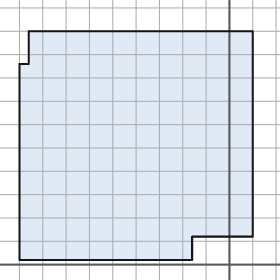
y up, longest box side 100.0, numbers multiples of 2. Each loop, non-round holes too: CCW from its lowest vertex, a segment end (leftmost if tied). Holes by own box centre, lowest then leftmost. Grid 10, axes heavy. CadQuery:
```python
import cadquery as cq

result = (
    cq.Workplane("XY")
    .moveTo(-90.0, 2.0)
    .lineTo(-16.0, 2.0)
    .lineTo(-16.0, 12.0)
    .lineTo(10.0, 12.0)
    .lineTo(10.0, 100.0)
    .lineTo(-86.0, 100.0)
    .lineTo(-86.0, 86.0)
    .lineTo(-90.0, 86.0)
    .close()
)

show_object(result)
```